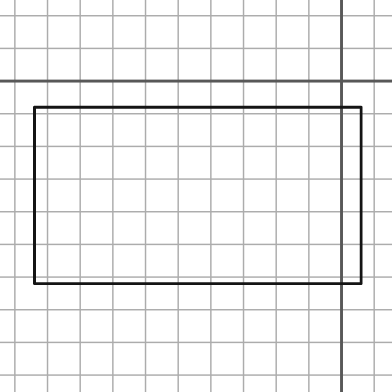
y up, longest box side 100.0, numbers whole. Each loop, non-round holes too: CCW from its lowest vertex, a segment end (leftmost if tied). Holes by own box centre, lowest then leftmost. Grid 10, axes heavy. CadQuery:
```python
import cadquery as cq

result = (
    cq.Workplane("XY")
    .moveTo(-94.0, -62.0)
    .lineTo(6.0, -62.0)
    .lineTo(6.0, -8.0)
    .lineTo(-94.0, -8.0)
    .close()
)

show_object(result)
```